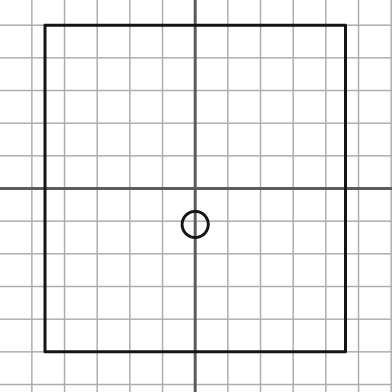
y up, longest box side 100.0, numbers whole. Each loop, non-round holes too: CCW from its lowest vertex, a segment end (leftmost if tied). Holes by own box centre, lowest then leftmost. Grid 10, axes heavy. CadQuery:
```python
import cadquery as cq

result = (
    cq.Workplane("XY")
    .moveTo(-46.0, -50.0)
    .lineTo(46.0, -50.0)
    .lineTo(46.0, 50.0)
    .lineTo(-46.0, 50.0)
    .close()
    .moveTo(0.0, -11.0)
    .circle(4.0)
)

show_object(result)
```